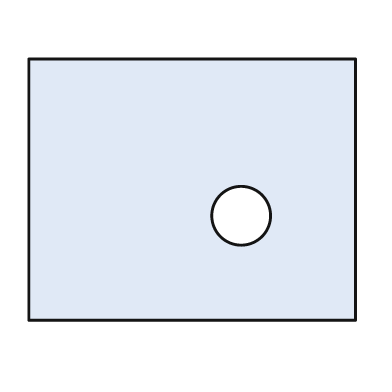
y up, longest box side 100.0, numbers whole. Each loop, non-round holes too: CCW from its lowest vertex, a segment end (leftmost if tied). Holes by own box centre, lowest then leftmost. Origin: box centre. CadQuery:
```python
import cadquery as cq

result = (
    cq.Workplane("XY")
    .moveTo(-50.0, -40.0)
    .lineTo(50.0, -40.0)
    .lineTo(50.0, 40.0)
    .lineTo(-50.0, 40.0)
    .close()
    .moveTo(15.0, -8.0)
    .circle(9.0)
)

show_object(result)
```